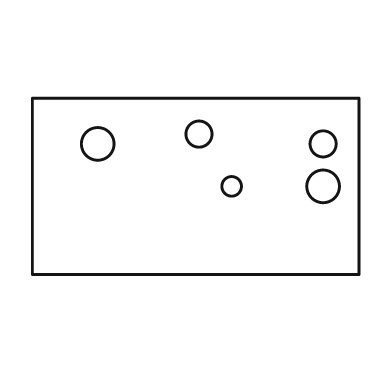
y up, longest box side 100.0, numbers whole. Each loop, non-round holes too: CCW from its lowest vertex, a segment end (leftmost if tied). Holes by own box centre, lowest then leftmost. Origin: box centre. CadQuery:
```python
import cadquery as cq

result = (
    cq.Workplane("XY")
    .moveTo(-50.0, -27.0)
    .lineTo(50.0, -27.0)
    .lineTo(50.0, 27.0)
    .lineTo(-50.0, 27.0)
    .close()
    .moveTo(11.0, 0.0)
    .circle(3.0)
    .moveTo(39.0, 0.0)
    .circle(5.0)
    .moveTo(-30.0, 13.0)
    .circle(5.0)
    .moveTo(39.0, 13.0)
    .circle(4.0)
    .moveTo(1.0, 16.0)
    .circle(4.0)
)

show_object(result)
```